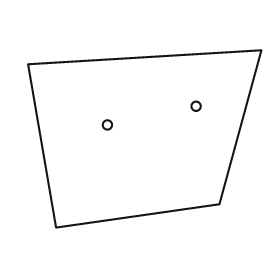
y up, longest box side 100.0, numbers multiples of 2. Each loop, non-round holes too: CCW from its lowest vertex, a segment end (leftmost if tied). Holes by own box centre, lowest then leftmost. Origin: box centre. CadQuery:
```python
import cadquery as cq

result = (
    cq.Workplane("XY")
    .moveTo(-38.0, -38.0)
    .lineTo(32.0, -28.0)
    .lineTo(50.0, 38.0)
    .lineTo(-50.0, 32.0)
    .close()
    .moveTo(-16.0, 6.0)
    .circle(2.0)
    .moveTo(22.0, 14.0)
    .circle(2.0)
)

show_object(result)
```